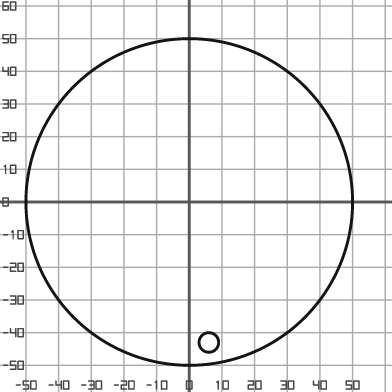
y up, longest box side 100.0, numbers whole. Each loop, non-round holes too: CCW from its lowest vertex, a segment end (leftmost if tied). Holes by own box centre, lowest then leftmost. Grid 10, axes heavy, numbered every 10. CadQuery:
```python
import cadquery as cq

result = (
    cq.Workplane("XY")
    .moveTo(0.0, 0.0)
    .circle(50.0)
    .moveTo(6.0, -43.0)
    .circle(3.0)
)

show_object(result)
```